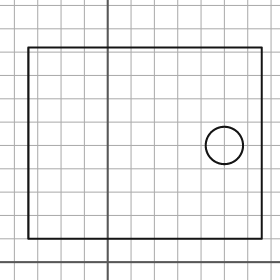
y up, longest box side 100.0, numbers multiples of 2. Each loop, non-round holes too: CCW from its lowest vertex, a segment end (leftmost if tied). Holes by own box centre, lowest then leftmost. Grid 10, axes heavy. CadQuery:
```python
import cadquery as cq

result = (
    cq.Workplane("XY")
    .moveTo(-34.0, 10.0)
    .lineTo(66.0, 10.0)
    .lineTo(66.0, 92.0)
    .lineTo(-34.0, 92.0)
    .close()
    .moveTo(50.0, 50.0)
    .circle(8.0)
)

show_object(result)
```